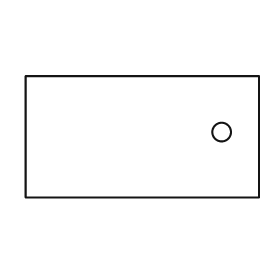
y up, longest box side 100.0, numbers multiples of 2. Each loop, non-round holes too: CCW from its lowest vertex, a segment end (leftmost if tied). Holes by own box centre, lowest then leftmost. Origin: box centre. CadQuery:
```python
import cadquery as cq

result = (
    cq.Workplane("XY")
    .moveTo(-50.0, -26.0)
    .lineTo(50.0, -26.0)
    .lineTo(50.0, 26.0)
    .lineTo(-50.0, 26.0)
    .close()
    .moveTo(34.0, 2.0)
    .circle(4.0)
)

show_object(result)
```